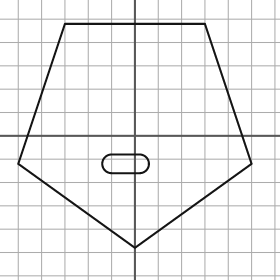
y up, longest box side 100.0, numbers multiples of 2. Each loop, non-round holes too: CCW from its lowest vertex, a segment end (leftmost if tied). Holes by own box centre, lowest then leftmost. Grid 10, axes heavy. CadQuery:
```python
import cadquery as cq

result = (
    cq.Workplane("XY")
    .moveTo(0.0, -48.0)
    .lineTo(50.0, -12.0)
    .lineTo(30.0, 48.0)
    .lineTo(-30.0, 48.0)
    .lineTo(-50.0, -12.0)
    .close()
    .moveTo(-10.0, -16.0)
    .lineTo(2.0, -16.0)
    .threePointArc((6.0, -12.0), (2.0, -8.0))
    .lineTo(-10.0, -8.0)
    .threePointArc((-14.0, -12.0), (-10.0, -16.0))
    .close()
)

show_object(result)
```